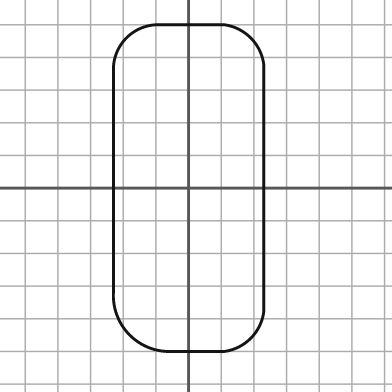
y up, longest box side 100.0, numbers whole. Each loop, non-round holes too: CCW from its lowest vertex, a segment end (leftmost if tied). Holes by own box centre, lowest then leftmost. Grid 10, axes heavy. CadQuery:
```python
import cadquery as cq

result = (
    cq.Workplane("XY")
    .moveTo(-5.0, -50.0)
    .lineTo(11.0, -50.0)
    .threePointArc((19.0, -46.0), (23.0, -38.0))
    .lineTo(23.0, 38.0)
    .threePointArc((19.0, 46.0), (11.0, 50.0))
    .lineTo(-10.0, 50.0)
    .threePointArc((-19.0, 46.0), (-23.0, 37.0))
    .lineTo(-23.0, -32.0)
    .threePointArc((-18.0, -45.0), (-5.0, -50.0))
    .close()
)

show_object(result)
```